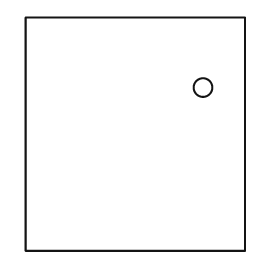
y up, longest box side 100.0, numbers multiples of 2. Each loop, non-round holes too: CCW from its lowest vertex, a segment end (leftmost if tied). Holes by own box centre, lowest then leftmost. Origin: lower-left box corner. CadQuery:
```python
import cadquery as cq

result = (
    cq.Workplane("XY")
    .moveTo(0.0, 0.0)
    .lineTo(94.0, 0.0)
    .lineTo(94.0, 100.0)
    .lineTo(0.0, 100.0)
    .close()
    .moveTo(76.0, 70.0)
    .circle(4.0)
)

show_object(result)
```